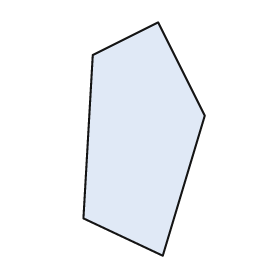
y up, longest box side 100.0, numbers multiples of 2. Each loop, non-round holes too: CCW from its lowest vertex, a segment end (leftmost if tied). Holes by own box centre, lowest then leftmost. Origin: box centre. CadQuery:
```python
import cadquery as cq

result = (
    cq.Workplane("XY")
    .moveTo(8.0, -50.0)
    .lineTo(26.0, 10.0)
    .lineTo(6.0, 50.0)
    .lineTo(-22.0, 36.0)
    .lineTo(-26.0, -34.0)
    .close()
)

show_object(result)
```